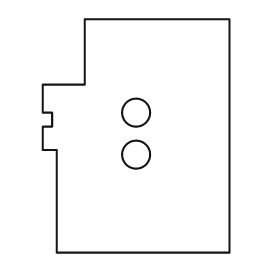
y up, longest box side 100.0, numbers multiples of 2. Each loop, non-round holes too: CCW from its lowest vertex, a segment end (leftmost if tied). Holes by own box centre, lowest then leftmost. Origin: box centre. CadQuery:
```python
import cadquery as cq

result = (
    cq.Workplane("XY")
    .moveTo(-34.0, -50.0)
    .lineTo(40.0, -50.0)
    .lineTo(40.0, 50.0)
    .lineTo(-22.0, 50.0)
    .lineTo(-22.0, 22.0)
    .lineTo(-40.0, 22.0)
    .lineTo(-40.0, 10.0)
    .lineTo(-36.0, 10.0)
    .lineTo(-36.0, 4.0)
    .lineTo(-40.0, 4.0)
    .lineTo(-40.0, -6.0)
    .lineTo(-34.0, -6.0)
    .close()
    .moveTo(0.0, -8.0)
    .circle(6.0)
    .moveTo(0.0, 10.0)
    .circle(6.0)
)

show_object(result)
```